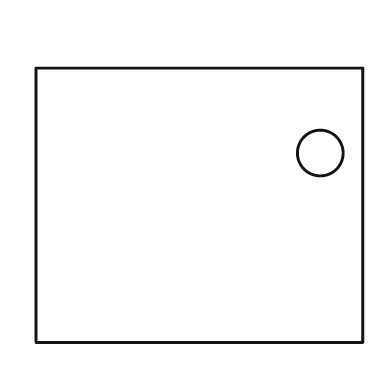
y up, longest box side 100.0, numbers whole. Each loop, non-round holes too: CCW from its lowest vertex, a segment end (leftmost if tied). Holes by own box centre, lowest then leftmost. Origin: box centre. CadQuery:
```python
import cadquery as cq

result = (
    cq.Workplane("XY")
    .moveTo(-50.0, -42.0)
    .lineTo(50.0, -42.0)
    .lineTo(50.0, 42.0)
    .lineTo(-50.0, 42.0)
    .close()
    .moveTo(37.0, 16.0)
    .circle(7.0)
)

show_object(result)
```